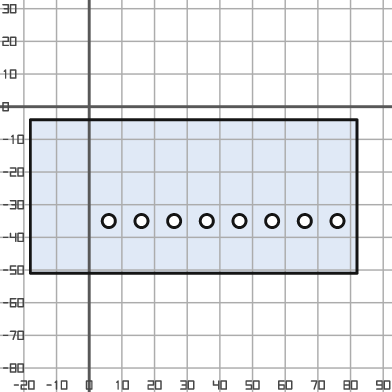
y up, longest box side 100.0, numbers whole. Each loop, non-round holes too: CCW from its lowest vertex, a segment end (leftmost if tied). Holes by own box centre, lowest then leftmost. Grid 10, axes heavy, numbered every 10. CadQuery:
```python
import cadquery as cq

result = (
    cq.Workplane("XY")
    .moveTo(-18.0, -51.0)
    .lineTo(82.0, -51.0)
    .lineTo(82.0, -4.0)
    .lineTo(-18.0, -4.0)
    .close()
    .moveTo(6.0, -35.0)
    .circle(2.0)
    .moveTo(16.0, -35.0)
    .circle(2.0)
    .moveTo(26.0, -35.0)
    .circle(2.0)
    .moveTo(36.0, -35.0)
    .circle(2.0)
    .moveTo(46.0, -35.0)
    .circle(2.0)
    .moveTo(56.0, -35.0)
    .circle(2.0)
    .moveTo(66.0, -35.0)
    .circle(2.0)
    .moveTo(76.0, -35.0)
    .circle(2.0)
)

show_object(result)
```